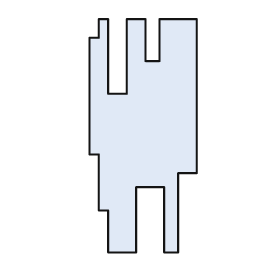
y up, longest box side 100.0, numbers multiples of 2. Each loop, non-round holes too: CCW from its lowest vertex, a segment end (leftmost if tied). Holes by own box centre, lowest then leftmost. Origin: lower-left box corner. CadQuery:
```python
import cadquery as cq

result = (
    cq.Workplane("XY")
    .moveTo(8.0, 0.0)
    .lineTo(20.0, 0.0)
    .lineTo(20.0, 28.0)
    .lineTo(32.0, 28.0)
    .lineTo(32.0, 0.0)
    .lineTo(38.0, 0.0)
    .lineTo(38.0, 34.0)
    .lineTo(46.0, 34.0)
    .lineTo(46.0, 100.0)
    .lineTo(30.0, 100.0)
    .lineTo(30.0, 82.0)
    .lineTo(24.0, 82.0)
    .lineTo(24.0, 100.0)
    .lineTo(16.0, 100.0)
    .lineTo(16.0, 68.0)
    .lineTo(8.0, 68.0)
    .lineTo(8.0, 100.0)
    .lineTo(4.0, 100.0)
    .lineTo(4.0, 92.0)
    .lineTo(0.0, 92.0)
    .lineTo(0.0, 42.0)
    .lineTo(4.0, 42.0)
    .lineTo(4.0, 18.0)
    .lineTo(8.0, 18.0)
    .close()
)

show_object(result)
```